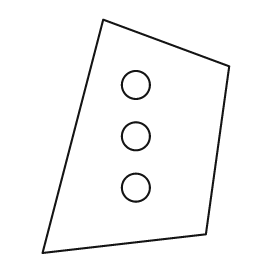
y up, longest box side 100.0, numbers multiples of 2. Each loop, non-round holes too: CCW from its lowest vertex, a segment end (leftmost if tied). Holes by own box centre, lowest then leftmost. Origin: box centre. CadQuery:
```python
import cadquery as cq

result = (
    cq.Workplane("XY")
    .moveTo(-40.0, -50.0)
    .lineTo(30.0, -42.0)
    .lineTo(40.0, 30.0)
    .lineTo(-14.0, 50.0)
    .close()
    .moveTo(0.0, -22.0)
    .circle(6.0)
    .moveTo(0.0, 0.0)
    .circle(6.0)
    .moveTo(0.0, 22.0)
    .circle(6.0)
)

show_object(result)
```